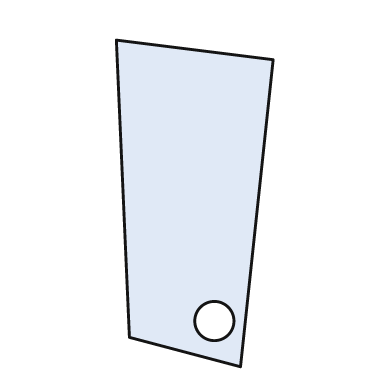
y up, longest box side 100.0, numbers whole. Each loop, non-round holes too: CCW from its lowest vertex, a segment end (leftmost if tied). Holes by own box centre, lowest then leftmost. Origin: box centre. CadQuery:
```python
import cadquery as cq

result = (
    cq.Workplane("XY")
    .moveTo(14.0, -50.0)
    .lineTo(24.0, 44.0)
    .lineTo(-24.0, 50.0)
    .lineTo(-20.0, -41.0)
    .close()
    .moveTo(6.0, -36.0)
    .circle(6.0)
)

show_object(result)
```